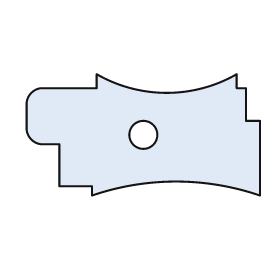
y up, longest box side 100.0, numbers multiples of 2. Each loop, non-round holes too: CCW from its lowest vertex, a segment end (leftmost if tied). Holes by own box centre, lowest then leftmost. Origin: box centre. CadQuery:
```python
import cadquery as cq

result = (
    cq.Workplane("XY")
    .moveTo(-22.0, -26.0)
    .threePointArc((14.0, -20.0), (50.0, -26.0))
    .lineTo(50.0, 6.0)
    .lineTo(44.0, 6.0)
    .lineTo(44.0, 20.0)
    .lineTo(40.0, 20.0)
    .lineTo(40.0, 26.0)
    .threePointArc((10.0, 18.0), (-20.0, 26.0))
    .lineTo(-20.0, 20.0)
    .lineTo(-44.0, 20.0)
    .threePointArc((-48.0, 18.0), (-50.0, 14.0))
    .lineTo(-50.0, 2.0)
    .threePointArc((-48.0, -2.0), (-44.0, -4.0))
    .lineTo(-36.0, -4.0)
    .lineTo(-36.0, -22.0)
    .lineTo(-22.0, -22.0)
    .close()
    .moveTo(0.0, 0.0)
    .circle(6.0)
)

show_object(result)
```